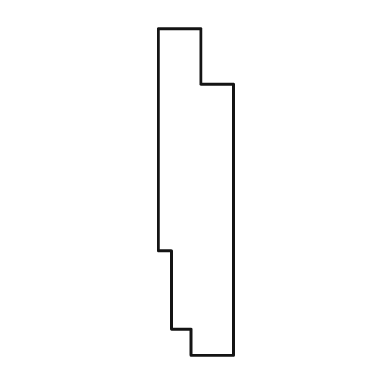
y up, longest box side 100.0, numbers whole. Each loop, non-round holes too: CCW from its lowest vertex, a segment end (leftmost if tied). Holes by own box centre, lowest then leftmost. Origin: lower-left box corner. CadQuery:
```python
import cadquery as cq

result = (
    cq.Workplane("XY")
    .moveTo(10.0, 0.0)
    .lineTo(23.0, 0.0)
    .lineTo(23.0, 83.0)
    .lineTo(13.0, 83.0)
    .lineTo(13.0, 100.0)
    .lineTo(0.0, 100.0)
    .lineTo(0.0, 32.0)
    .lineTo(4.0, 32.0)
    .lineTo(4.0, 8.0)
    .lineTo(10.0, 8.0)
    .close()
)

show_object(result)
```